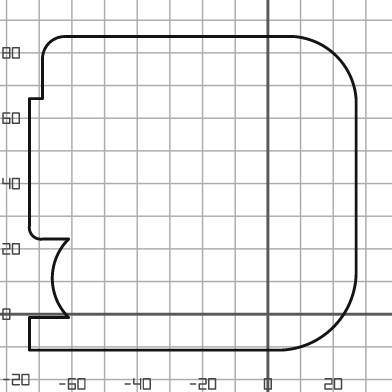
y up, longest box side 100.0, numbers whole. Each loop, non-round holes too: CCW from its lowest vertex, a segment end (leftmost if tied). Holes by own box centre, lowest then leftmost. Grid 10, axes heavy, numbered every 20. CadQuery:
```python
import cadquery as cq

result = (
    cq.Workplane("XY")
    .moveTo(-73.0, -11.0)
    .lineTo(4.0, -11.0)
    .threePointArc((20.0, -4.0), (27.0, 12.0))
    .lineTo(27.0, 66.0)
    .threePointArc((21.0, 79.0), (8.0, 85.0))
    .lineTo(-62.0, 85.0)
    .threePointArc((-67.0, 83.0), (-69.0, 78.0))
    .lineTo(-69.0, 66.0)
    .lineTo(-73.0, 66.0)
    .lineTo(-73.0, 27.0)
    .threePointArc((-72.0, 24.0), (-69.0, 23.0))
    .lineTo(-61.0, 23.0)
    .threePointArc((-66.0, 11.0), (-61.0, -1.0))
    .lineTo(-73.0, -1.0)
    .close()
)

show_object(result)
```